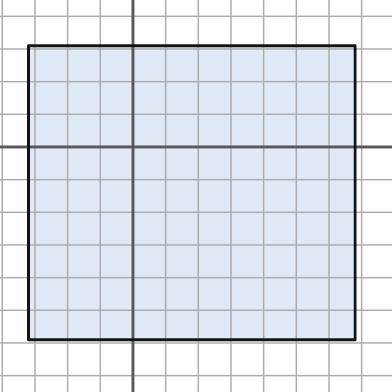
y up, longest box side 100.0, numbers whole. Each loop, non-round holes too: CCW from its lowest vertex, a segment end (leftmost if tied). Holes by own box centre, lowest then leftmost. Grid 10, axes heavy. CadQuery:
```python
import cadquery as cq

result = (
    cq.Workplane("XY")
    .moveTo(-32.0, -59.0)
    .lineTo(68.0, -59.0)
    .lineTo(68.0, 31.0)
    .lineTo(-32.0, 31.0)
    .close()
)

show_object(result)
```